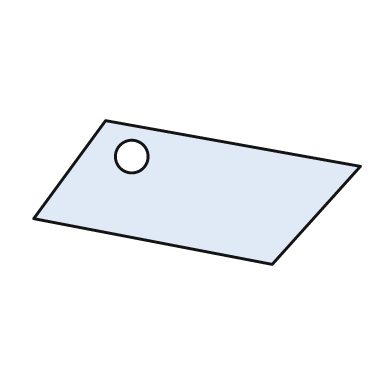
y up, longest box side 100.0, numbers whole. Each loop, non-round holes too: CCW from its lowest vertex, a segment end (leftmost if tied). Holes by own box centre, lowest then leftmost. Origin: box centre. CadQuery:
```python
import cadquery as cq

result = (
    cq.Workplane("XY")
    .moveTo(23.0, -22.0)
    .lineTo(50.0, 8.0)
    .lineTo(-28.0, 22.0)
    .lineTo(-50.0, -8.0)
    .close()
    .moveTo(-20.0, 11.0)
    .circle(5.0)
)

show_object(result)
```